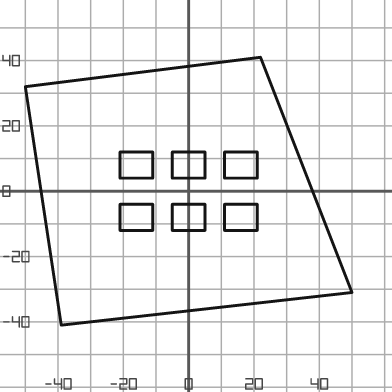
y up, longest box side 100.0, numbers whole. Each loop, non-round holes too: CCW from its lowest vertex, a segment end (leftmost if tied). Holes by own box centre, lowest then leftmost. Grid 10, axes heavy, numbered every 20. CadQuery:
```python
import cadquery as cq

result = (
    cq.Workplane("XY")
    .moveTo(-39.0, -41.0)
    .lineTo(50.0, -31.0)
    .lineTo(22.0, 41.0)
    .lineTo(-50.0, 32.0)
    .close()
    .moveTo(-21.0, -12.0)
    .lineTo(-11.0, -12.0)
    .lineTo(-11.0, -4.0)
    .lineTo(-21.0, -4.0)
    .close()
    .moveTo(-5.0, -12.0)
    .lineTo(5.0, -12.0)
    .lineTo(5.0, -4.0)
    .lineTo(-5.0, -4.0)
    .close()
    .moveTo(11.0, -12.0)
    .lineTo(21.0, -12.0)
    .lineTo(21.0, -4.0)
    .lineTo(11.0, -4.0)
    .close()
    .moveTo(-21.0, 4.0)
    .lineTo(-11.0, 4.0)
    .lineTo(-11.0, 12.0)
    .lineTo(-21.0, 12.0)
    .close()
    .moveTo(-5.0, 4.0)
    .lineTo(5.0, 4.0)
    .lineTo(5.0, 12.0)
    .lineTo(-5.0, 12.0)
    .close()
    .moveTo(11.0, 4.0)
    .lineTo(21.0, 4.0)
    .lineTo(21.0, 12.0)
    .lineTo(11.0, 12.0)
    .close()
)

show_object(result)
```